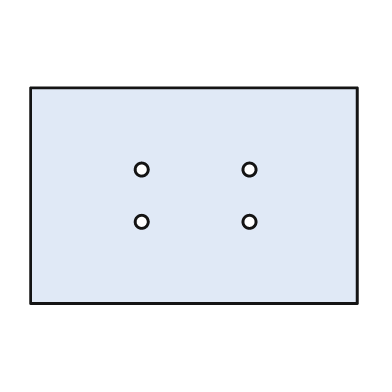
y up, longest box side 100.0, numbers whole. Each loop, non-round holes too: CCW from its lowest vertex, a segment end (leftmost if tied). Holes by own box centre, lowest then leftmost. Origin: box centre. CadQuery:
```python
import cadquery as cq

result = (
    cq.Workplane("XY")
    .moveTo(-50.0, -33.0)
    .lineTo(50.0, -33.0)
    .lineTo(50.0, 33.0)
    .lineTo(-50.0, 33.0)
    .close()
    .moveTo(-16.0, -8.0)
    .circle(2.0)
    .moveTo(17.0, -8.0)
    .circle(2.0)
    .moveTo(-16.0, 8.0)
    .circle(2.0)
    .moveTo(17.0, 8.0)
    .circle(2.0)
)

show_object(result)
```